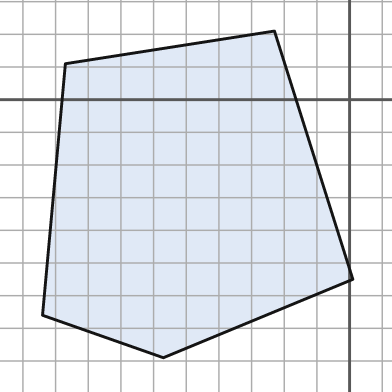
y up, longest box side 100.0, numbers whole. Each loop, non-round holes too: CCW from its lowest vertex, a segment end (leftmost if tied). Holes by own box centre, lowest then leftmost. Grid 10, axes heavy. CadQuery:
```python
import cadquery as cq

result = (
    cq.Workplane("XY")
    .moveTo(-57.0, -79.0)
    .lineTo(1.0, -55.0)
    .lineTo(-23.0, 21.0)
    .lineTo(-87.0, 11.0)
    .lineTo(-94.0, -66.0)
    .close()
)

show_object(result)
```